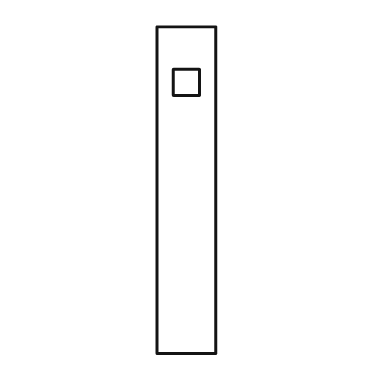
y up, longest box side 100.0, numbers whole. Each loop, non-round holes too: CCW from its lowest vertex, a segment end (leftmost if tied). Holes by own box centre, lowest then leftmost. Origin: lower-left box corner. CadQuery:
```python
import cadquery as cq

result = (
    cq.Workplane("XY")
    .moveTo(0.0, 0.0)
    .lineTo(18.0, 0.0)
    .lineTo(18.0, 100.0)
    .lineTo(0.0, 100.0)
    .close()
    .moveTo(5.0, 79.0)
    .lineTo(13.0, 79.0)
    .lineTo(13.0, 87.0)
    .lineTo(5.0, 87.0)
    .close()
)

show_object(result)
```